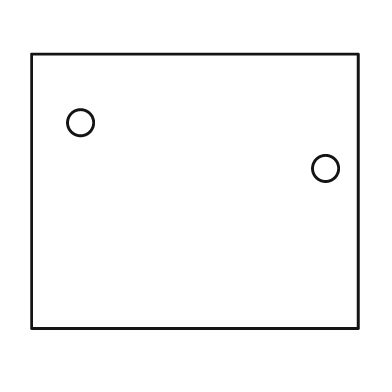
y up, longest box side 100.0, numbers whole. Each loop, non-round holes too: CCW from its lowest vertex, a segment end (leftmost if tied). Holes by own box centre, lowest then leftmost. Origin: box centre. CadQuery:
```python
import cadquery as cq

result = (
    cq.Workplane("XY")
    .moveTo(-50.0, -42.0)
    .lineTo(50.0, -42.0)
    .lineTo(50.0, 42.0)
    .lineTo(-50.0, 42.0)
    .close()
    .moveTo(40.0, 7.0)
    .circle(4.0)
    .moveTo(-35.0, 21.0)
    .circle(4.0)
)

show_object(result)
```